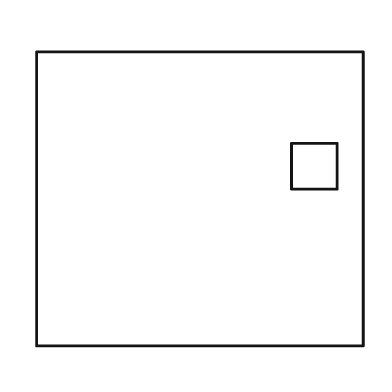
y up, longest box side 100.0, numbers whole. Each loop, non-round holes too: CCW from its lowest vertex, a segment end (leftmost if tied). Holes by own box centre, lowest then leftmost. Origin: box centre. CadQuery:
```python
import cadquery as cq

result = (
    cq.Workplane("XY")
    .moveTo(-50.0, -45.0)
    .lineTo(50.0, -45.0)
    .lineTo(50.0, 45.0)
    .lineTo(-50.0, 45.0)
    .close()
    .moveTo(28.0, 3.0)
    .lineTo(42.0, 3.0)
    .lineTo(42.0, 17.0)
    .lineTo(28.0, 17.0)
    .close()
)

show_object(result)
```